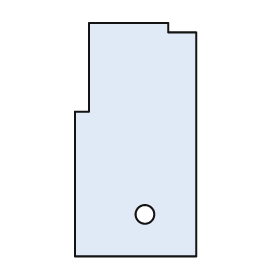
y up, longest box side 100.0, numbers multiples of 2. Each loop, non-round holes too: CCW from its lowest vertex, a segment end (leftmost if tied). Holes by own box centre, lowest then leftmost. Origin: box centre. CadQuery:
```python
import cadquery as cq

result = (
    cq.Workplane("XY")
    .moveTo(-26.0, -50.0)
    .lineTo(26.0, -50.0)
    .lineTo(26.0, 46.0)
    .lineTo(14.0, 46.0)
    .lineTo(14.0, 50.0)
    .lineTo(-20.0, 50.0)
    .lineTo(-20.0, 12.0)
    .lineTo(-26.0, 12.0)
    .close()
    .moveTo(4.0, -32.0)
    .circle(4.0)
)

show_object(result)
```